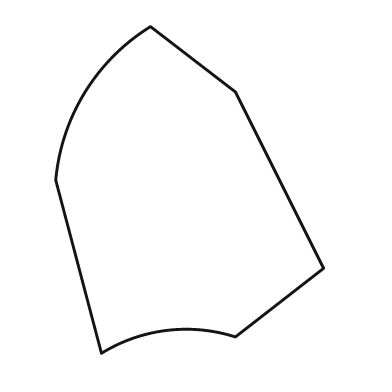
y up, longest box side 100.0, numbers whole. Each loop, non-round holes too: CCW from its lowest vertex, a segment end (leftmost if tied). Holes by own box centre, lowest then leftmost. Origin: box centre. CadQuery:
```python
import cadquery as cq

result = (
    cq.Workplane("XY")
    .moveTo(-27.0, -50.0)
    .threePointArc((-7.0, -43.0), (14.0, -45.0))
    .lineTo(41.0, -24.0)
    .lineTo(14.0, 30.0)
    .lineTo(-12.0, 50.0)
    .threePointArc((-32.0, 30.0), (-41.0, 3.0))
    .close()
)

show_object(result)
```